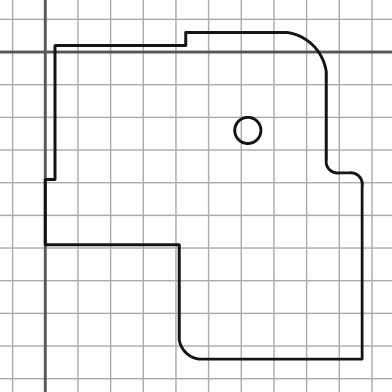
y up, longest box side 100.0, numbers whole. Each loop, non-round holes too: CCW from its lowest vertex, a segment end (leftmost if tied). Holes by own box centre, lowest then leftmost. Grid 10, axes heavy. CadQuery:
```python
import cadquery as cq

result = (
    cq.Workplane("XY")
    .moveTo(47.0, -94.0)
    .lineTo(97.0, -94.0)
    .lineTo(97.0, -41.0)
    .threePointArc((96.0, -38.0), (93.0, -37.0))
    .lineTo(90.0, -37.0)
    .threePointArc((87.0, -36.0), (86.0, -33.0))
    .lineTo(86.0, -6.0)
    .threePointArc((82.0, 2.0), (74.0, 6.0))
    .lineTo(43.0, 6.0)
    .lineTo(43.0, 2.0)
    .lineTo(3.0, 2.0)
    .lineTo(3.0, -39.0)
    .lineTo(0.0, -39.0)
    .lineTo(0.0, -59.0)
    .lineTo(41.0, -59.0)
    .lineTo(41.0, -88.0)
    .threePointArc((43.0, -92.0), (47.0, -94.0))
    .close()
    .moveTo(62.0, -24.0)
    .circle(4.0)
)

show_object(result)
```